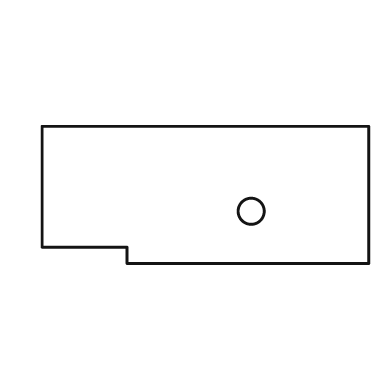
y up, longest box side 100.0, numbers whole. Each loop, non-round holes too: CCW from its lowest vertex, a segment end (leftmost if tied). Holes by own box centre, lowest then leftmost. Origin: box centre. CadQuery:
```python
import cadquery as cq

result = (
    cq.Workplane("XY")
    .moveTo(-24.0, -21.0)
    .lineTo(50.0, -21.0)
    .lineTo(50.0, 21.0)
    .lineTo(-50.0, 21.0)
    .lineTo(-50.0, -16.0)
    .lineTo(-24.0, -16.0)
    .close()
    .moveTo(14.0, -5.0)
    .circle(4.0)
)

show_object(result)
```